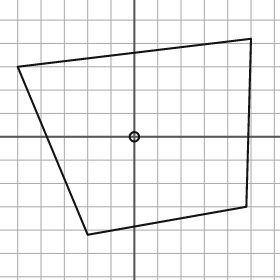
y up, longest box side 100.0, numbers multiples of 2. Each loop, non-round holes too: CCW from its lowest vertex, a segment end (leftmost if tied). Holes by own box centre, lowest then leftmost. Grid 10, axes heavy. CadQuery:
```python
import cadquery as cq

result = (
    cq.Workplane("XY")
    .moveTo(-20.0, -42.0)
    .lineTo(48.0, -30.0)
    .lineTo(50.0, 42.0)
    .lineTo(-50.0, 30.0)
    .close()
    .moveTo(0.0, 0.0)
    .circle(2.0)
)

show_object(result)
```